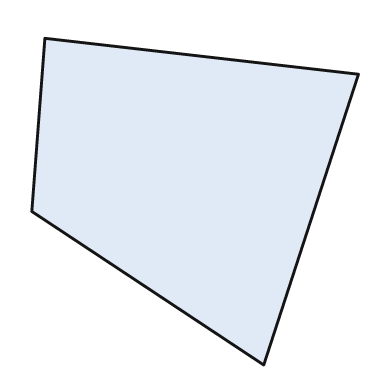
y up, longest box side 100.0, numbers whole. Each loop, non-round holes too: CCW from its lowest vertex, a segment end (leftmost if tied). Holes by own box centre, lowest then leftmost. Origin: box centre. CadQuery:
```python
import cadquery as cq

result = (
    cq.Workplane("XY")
    .moveTo(21.0, -50.0)
    .lineTo(50.0, 39.0)
    .lineTo(-46.0, 50.0)
    .lineTo(-50.0, -3.0)
    .close()
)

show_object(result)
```